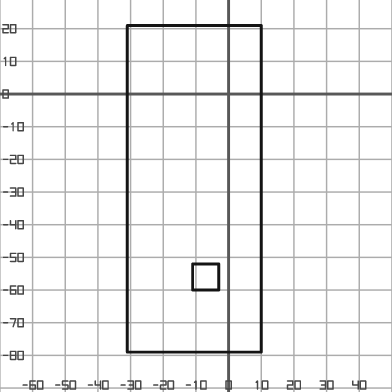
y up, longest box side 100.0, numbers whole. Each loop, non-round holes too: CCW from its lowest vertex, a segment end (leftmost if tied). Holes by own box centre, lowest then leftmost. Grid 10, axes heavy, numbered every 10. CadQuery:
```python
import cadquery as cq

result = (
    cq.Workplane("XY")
    .moveTo(-31.0, -79.0)
    .lineTo(10.0, -79.0)
    .lineTo(10.0, 21.0)
    .lineTo(-31.0, 21.0)
    .close()
    .moveTo(-11.0, -60.0)
    .lineTo(-3.0, -60.0)
    .lineTo(-3.0, -52.0)
    .lineTo(-11.0, -52.0)
    .close()
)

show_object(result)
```